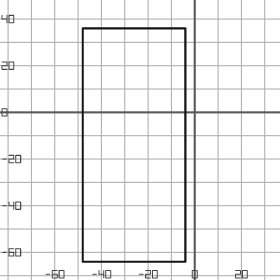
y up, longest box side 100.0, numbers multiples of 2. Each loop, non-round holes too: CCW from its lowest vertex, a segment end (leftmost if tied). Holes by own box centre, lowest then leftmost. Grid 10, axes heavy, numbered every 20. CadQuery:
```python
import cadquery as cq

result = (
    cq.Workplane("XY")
    .moveTo(-48.0, -64.0)
    .lineTo(-4.0, -64.0)
    .lineTo(-4.0, 36.0)
    .lineTo(-48.0, 36.0)
    .close()
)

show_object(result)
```